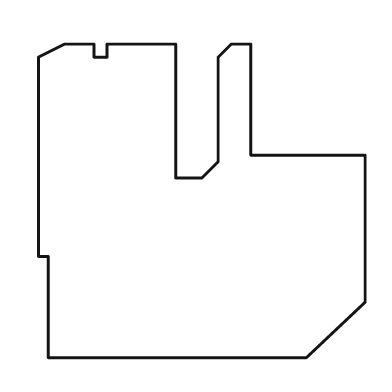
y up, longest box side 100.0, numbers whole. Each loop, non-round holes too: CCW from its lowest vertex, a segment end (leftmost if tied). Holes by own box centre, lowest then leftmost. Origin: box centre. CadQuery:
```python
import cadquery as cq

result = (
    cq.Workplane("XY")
    .moveTo(-47.0, -48.0)
    .lineTo(32.0, -48.0)
    .lineTo(50.0, -31.0)
    .lineTo(50.0, 14.0)
    .lineTo(15.0, 14.0)
    .lineTo(15.0, 48.0)
    .lineTo(9.0, 48.0)
    .lineTo(5.0, 44.0)
    .lineTo(5.0, 12.0)
    .lineTo(0.0, 7.0)
    .lineTo(-8.0, 7.0)
    .lineTo(-8.0, 48.0)
    .lineTo(-29.0, 48.0)
    .lineTo(-29.0, 44.0)
    .lineTo(-33.0, 44.0)
    .lineTo(-33.0, 48.0)
    .lineTo(-42.0, 48.0)
    .lineTo(-50.0, 44.0)
    .lineTo(-50.0, -17.0)
    .lineTo(-47.0, -17.0)
    .close()
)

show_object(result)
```